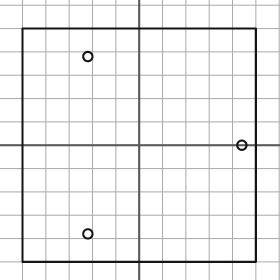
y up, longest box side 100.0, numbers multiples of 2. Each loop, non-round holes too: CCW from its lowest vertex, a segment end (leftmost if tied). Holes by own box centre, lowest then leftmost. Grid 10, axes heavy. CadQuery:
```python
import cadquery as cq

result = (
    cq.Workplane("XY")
    .moveTo(-50.0, -50.0)
    .lineTo(50.0, -50.0)
    .lineTo(50.0, 50.0)
    .lineTo(-50.0, 50.0)
    .close()
    .moveTo(-22.0, -38.0)
    .circle(2.0)
    .moveTo(44.0, 0.0)
    .circle(2.0)
    .moveTo(-22.0, 38.0)
    .circle(2.0)
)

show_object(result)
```